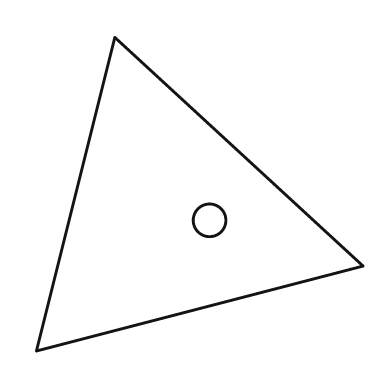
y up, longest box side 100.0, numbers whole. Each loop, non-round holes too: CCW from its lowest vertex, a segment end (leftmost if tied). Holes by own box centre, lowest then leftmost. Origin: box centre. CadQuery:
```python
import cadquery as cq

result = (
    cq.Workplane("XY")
    .moveTo(-50.0, -48.0)
    .lineTo(50.0, -22.0)
    .lineTo(-26.0, 48.0)
    .close()
    .moveTo(3.0, -8.0)
    .circle(5.0)
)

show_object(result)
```